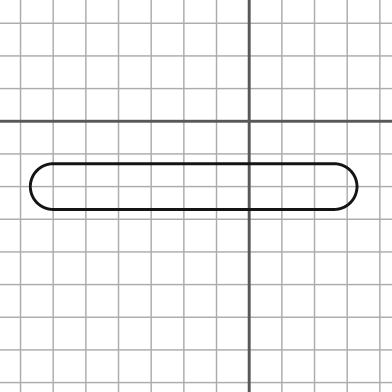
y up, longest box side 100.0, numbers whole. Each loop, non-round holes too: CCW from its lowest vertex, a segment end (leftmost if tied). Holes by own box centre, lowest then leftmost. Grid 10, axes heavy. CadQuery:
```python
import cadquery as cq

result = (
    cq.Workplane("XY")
    .moveTo(-60.0, -27.0)
    .lineTo(26.0, -27.0)
    .threePointArc((33.0, -20.0), (26.0, -13.0))
    .lineTo(-60.0, -13.0)
    .threePointArc((-67.0, -20.0), (-60.0, -27.0))
    .close()
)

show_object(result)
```